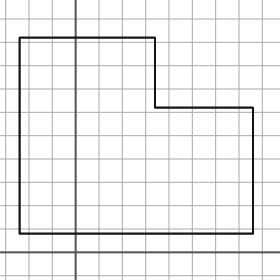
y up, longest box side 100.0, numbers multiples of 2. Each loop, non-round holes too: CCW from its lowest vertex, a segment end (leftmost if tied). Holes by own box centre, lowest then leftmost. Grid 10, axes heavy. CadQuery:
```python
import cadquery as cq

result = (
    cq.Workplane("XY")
    .moveTo(-24.0, 8.0)
    .lineTo(76.0, 8.0)
    .lineTo(76.0, 62.0)
    .lineTo(34.0, 62.0)
    .lineTo(34.0, 92.0)
    .lineTo(-24.0, 92.0)
    .close()
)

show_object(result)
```